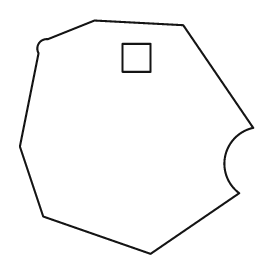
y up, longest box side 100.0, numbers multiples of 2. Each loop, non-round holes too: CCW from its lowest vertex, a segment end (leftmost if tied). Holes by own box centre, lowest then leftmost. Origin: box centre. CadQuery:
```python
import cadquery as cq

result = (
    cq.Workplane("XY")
    .moveTo(6.0, -50.0)
    .lineTo(44.0, -24.0)
    .threePointArc((38.0, -8.0), (50.0, 4.0))
    .lineTo(20.0, 48.0)
    .lineTo(-18.0, 50.0)
    .lineTo(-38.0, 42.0)
    .threePointArc((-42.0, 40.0), (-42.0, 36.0))
    .lineTo(-50.0, -4.0)
    .lineTo(-40.0, -34.0)
    .close()
    .moveTo(-6.0, 28.0)
    .lineTo(6.0, 28.0)
    .lineTo(6.0, 40.0)
    .lineTo(-6.0, 40.0)
    .close()
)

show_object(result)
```